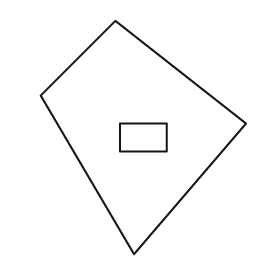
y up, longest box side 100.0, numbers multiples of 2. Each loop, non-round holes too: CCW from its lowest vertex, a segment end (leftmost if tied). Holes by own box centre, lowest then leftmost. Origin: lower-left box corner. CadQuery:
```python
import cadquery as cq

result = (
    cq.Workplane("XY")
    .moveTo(40.0, 0.0)
    .lineTo(88.0, 56.0)
    .lineTo(32.0, 100.0)
    .lineTo(0.0, 68.0)
    .close()
    .moveTo(34.0, 44.0)
    .lineTo(54.0, 44.0)
    .lineTo(54.0, 56.0)
    .lineTo(34.0, 56.0)
    .close()
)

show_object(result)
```